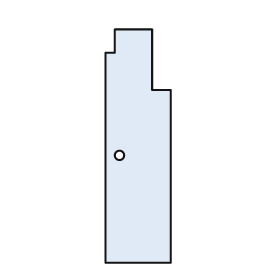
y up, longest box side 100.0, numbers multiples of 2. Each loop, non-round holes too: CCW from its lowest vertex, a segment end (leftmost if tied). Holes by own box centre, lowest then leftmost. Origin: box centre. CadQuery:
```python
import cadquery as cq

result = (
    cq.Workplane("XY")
    .moveTo(-14.0, -50.0)
    .lineTo(14.0, -50.0)
    .lineTo(14.0, 24.0)
    .lineTo(6.0, 24.0)
    .lineTo(6.0, 50.0)
    .lineTo(-10.0, 50.0)
    .lineTo(-10.0, 40.0)
    .lineTo(-14.0, 40.0)
    .close()
    .moveTo(-8.0, -4.0)
    .circle(2.0)
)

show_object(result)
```